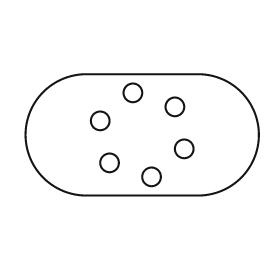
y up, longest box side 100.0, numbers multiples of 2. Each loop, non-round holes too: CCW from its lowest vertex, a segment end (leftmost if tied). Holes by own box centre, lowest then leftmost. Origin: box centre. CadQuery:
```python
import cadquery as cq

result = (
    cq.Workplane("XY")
    .moveTo(-24.0, -26.0)
    .lineTo(24.0, -26.0)
    .threePointArc((50.0, 0.0), (24.0, 26.0))
    .lineTo(-24.0, 26.0)
    .threePointArc((-50.0, 0.0), (-24.0, -26.0))
    .close()
    .moveTo(4.0, -18.0)
    .circle(4.0)
    .moveTo(-14.0, -12.0)
    .circle(4.0)
    .moveTo(18.0, -6.0)
    .circle(4.0)
    .moveTo(-18.0, 6.0)
    .circle(4.0)
    .moveTo(14.0, 12.0)
    .circle(4.0)
    .moveTo(-4.0, 18.0)
    .circle(4.0)
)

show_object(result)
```